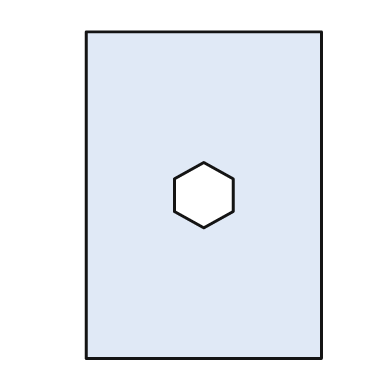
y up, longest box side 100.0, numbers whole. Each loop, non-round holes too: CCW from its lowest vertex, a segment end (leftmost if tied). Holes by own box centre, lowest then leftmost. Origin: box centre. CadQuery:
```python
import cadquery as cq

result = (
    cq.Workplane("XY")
    .moveTo(-36.0, -50.0)
    .lineTo(36.0, -50.0)
    .lineTo(36.0, 50.0)
    .lineTo(-36.0, 50.0)
    .close()
    .moveTo(0.0, -10.0)
    .lineTo(9.0, -5.0)
    .lineTo(9.0, 5.0)
    .lineTo(0.0, 10.0)
    .lineTo(-9.0, 5.0)
    .lineTo(-9.0, -5.0)
    .close()
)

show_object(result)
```